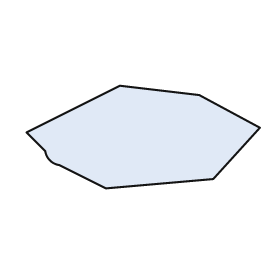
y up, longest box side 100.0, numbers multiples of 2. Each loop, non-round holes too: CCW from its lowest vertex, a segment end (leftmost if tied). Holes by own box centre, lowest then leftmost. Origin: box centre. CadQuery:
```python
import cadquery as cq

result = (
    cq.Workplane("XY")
    .moveTo(-16.0, -22.0)
    .lineTo(30.0, -18.0)
    .lineTo(50.0, 4.0)
    .lineTo(24.0, 18.0)
    .lineTo(-10.0, 22.0)
    .lineTo(-50.0, 2.0)
    .lineTo(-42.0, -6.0)
    .threePointArc((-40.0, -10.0), (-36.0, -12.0))
    .close()
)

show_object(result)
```